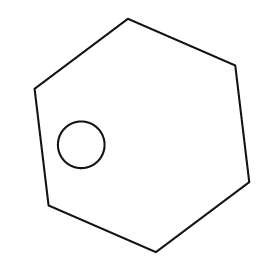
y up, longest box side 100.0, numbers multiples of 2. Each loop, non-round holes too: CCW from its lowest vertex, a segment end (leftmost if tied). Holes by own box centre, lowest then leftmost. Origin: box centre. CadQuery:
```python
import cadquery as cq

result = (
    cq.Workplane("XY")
    .moveTo(6.0, -50.0)
    .lineTo(46.0, -20.0)
    .lineTo(40.0, 30.0)
    .lineTo(-6.0, 50.0)
    .lineTo(-46.0, 20.0)
    .lineTo(-40.0, -30.0)
    .close()
    .moveTo(-26.0, -4.0)
    .circle(10.0)
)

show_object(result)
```